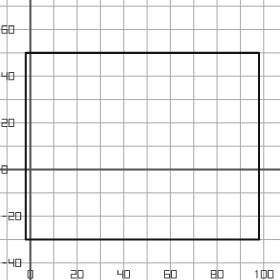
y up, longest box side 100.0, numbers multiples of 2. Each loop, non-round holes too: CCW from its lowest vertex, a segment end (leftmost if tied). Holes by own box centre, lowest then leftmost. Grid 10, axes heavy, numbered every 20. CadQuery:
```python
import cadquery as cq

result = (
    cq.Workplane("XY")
    .moveTo(-2.0, -30.0)
    .lineTo(98.0, -30.0)
    .lineTo(98.0, 50.0)
    .lineTo(-2.0, 50.0)
    .close()
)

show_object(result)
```